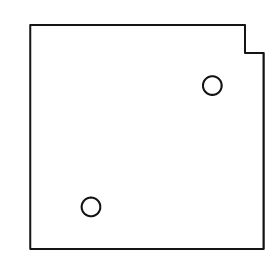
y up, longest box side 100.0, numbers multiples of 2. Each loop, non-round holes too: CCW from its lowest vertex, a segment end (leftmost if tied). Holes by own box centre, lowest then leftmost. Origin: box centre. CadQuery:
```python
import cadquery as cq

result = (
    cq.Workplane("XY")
    .moveTo(-50.0, -48.0)
    .lineTo(50.0, -48.0)
    .lineTo(50.0, 36.0)
    .lineTo(42.0, 36.0)
    .lineTo(42.0, 48.0)
    .lineTo(-50.0, 48.0)
    .close()
    .moveTo(-24.0, -30.0)
    .circle(4.0)
    .moveTo(28.0, 22.0)
    .circle(4.0)
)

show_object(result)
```